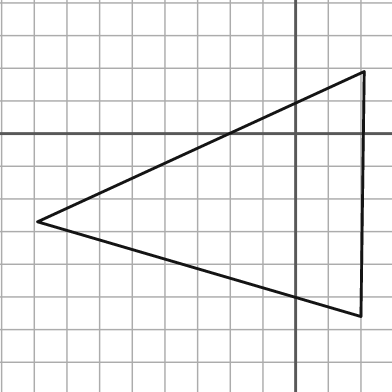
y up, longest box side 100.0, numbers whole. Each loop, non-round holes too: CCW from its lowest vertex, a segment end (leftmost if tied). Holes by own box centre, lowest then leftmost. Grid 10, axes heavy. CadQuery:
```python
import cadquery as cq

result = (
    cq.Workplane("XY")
    .moveTo(20.0, -56.0)
    .lineTo(21.0, 19.0)
    .lineTo(-79.0, -27.0)
    .close()
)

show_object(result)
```